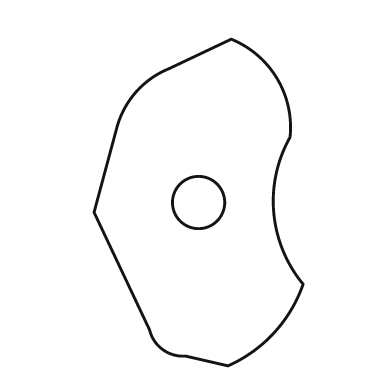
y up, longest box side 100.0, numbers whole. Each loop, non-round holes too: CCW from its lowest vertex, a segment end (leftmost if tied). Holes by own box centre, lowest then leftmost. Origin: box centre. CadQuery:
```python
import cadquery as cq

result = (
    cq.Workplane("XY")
    .moveTo(9.0, -50.0)
    .threePointArc((23.0, -40.0), (32.0, -25.0))
    .threePointArc((23.0, -3.0), (28.0, 20.0))
    .threePointArc((24.0, 38.0), (10.0, 50.0))
    .lineTo(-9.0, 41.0)
    .threePointArc((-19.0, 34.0), (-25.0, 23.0))
    .lineTo(-32.0, -3.0)
    .lineTo(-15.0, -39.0)
    .threePointArc((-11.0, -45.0), (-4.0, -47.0))
    .close()
    .moveTo(0.0, 0.0)
    .circle(8.0)
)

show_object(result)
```